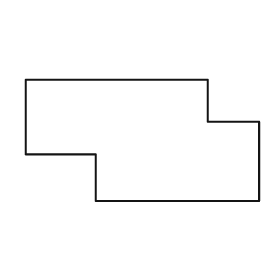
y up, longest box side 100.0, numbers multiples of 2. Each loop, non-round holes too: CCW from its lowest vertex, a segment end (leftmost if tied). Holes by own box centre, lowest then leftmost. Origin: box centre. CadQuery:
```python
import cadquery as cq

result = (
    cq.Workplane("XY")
    .moveTo(-20.0, -26.0)
    .lineTo(50.0, -26.0)
    .lineTo(50.0, 8.0)
    .lineTo(28.0, 8.0)
    .lineTo(28.0, 26.0)
    .lineTo(-50.0, 26.0)
    .lineTo(-50.0, -6.0)
    .lineTo(-20.0, -6.0)
    .close()
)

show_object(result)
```